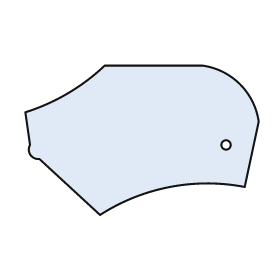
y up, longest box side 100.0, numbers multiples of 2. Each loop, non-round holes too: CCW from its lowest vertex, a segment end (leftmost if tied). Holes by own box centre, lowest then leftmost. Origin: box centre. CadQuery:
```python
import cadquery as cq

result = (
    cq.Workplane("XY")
    .moveTo(-18.0, -32.0)
    .threePointArc((12.0, -20.0), (44.0, -20.0))
    .lineTo(50.0, 8.0)
    .threePointArc((42.0, 24.0), (26.0, 32.0))
    .lineTo(-16.0, 32.0)
    .threePointArc((-32.0, 20.0), (-50.0, 12.0))
    .lineTo(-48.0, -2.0)
    .threePointArc((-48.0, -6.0), (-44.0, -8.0))
    .close()
    .moveTo(36.0, -2.0)
    .circle(2.0)
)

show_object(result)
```